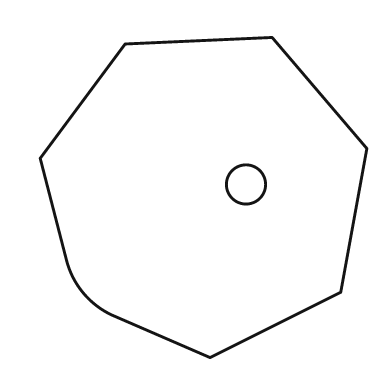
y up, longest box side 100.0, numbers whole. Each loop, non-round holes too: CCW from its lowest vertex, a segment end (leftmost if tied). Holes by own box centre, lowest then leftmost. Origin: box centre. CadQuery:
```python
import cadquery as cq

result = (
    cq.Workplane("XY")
    .moveTo(2.0, -49.0)
    .lineTo(42.0, -29.0)
    .lineTo(50.0, 15.0)
    .lineTo(21.0, 49.0)
    .lineTo(-24.0, 47.0)
    .lineTo(-50.0, 12.0)
    .lineTo(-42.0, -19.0)
    .threePointArc((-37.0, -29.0), (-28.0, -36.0))
    .close()
    .moveTo(13.0, 4.0)
    .circle(6.0)
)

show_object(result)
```